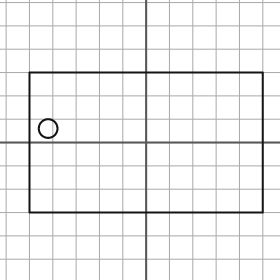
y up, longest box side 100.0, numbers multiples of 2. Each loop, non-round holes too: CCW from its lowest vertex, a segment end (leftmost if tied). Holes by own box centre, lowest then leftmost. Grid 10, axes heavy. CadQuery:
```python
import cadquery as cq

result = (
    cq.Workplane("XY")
    .moveTo(-50.0, -30.0)
    .lineTo(50.0, -30.0)
    .lineTo(50.0, 30.0)
    .lineTo(-50.0, 30.0)
    .close()
    .moveTo(-42.0, 6.0)
    .circle(4.0)
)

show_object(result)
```